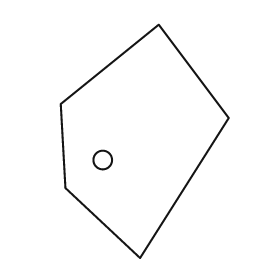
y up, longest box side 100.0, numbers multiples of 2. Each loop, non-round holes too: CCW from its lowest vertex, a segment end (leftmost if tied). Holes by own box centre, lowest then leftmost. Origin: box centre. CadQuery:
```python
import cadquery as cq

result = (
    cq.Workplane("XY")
    .moveTo(-2.0, -50.0)
    .lineTo(36.0, 10.0)
    .lineTo(6.0, 50.0)
    .lineTo(-36.0, 16.0)
    .lineTo(-34.0, -20.0)
    .close()
    .moveTo(-18.0, -8.0)
    .circle(4.0)
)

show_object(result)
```